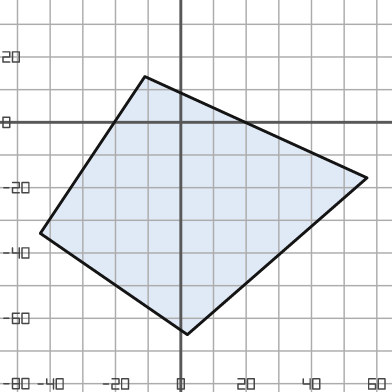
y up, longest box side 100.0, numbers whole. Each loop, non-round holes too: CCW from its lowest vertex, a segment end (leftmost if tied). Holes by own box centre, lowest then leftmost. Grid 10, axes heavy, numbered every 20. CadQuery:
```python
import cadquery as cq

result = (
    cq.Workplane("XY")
    .moveTo(2.0, -65.0)
    .lineTo(57.0, -17.0)
    .lineTo(-11.0, 14.0)
    .lineTo(-43.0, -34.0)
    .close()
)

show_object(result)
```